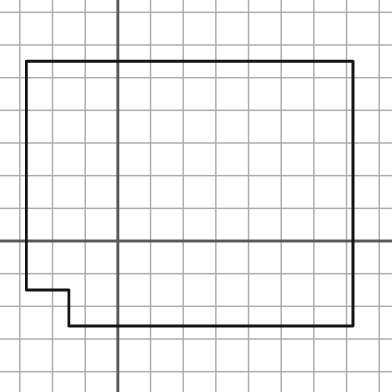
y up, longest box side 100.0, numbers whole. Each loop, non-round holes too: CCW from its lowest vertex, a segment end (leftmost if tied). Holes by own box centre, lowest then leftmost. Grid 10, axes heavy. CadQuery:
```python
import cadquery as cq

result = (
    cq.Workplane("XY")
    .moveTo(-15.0, -26.0)
    .lineTo(72.0, -26.0)
    .lineTo(72.0, 55.0)
    .lineTo(-28.0, 55.0)
    .lineTo(-28.0, -15.0)
    .lineTo(-15.0, -15.0)
    .close()
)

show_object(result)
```